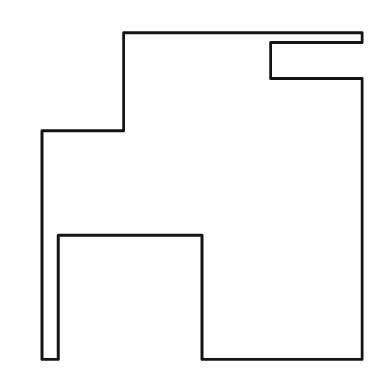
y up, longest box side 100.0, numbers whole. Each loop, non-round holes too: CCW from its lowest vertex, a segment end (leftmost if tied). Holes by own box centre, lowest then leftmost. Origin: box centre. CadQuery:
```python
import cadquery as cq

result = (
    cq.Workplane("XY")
    .moveTo(-49.0, -50.0)
    .lineTo(-44.0, -50.0)
    .lineTo(-44.0, -12.0)
    .lineTo(0.0, -12.0)
    .lineTo(0.0, -50.0)
    .lineTo(49.0, -50.0)
    .lineTo(49.0, 36.0)
    .lineTo(21.0, 36.0)
    .lineTo(21.0, 47.0)
    .lineTo(49.0, 47.0)
    .lineTo(49.0, 50.0)
    .lineTo(-24.0, 50.0)
    .lineTo(-24.0, 20.0)
    .lineTo(-49.0, 20.0)
    .close()
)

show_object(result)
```